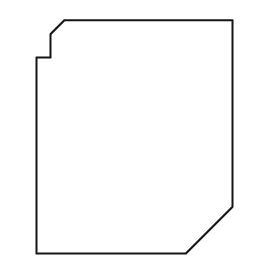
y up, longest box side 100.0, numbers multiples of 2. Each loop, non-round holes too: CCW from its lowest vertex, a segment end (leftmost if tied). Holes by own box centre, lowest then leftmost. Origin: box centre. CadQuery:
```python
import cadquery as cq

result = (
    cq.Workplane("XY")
    .moveTo(-42.0, -50.0)
    .lineTo(22.0, -50.0)
    .lineTo(42.0, -30.0)
    .lineTo(42.0, 50.0)
    .lineTo(-30.0, 50.0)
    .lineTo(-36.0, 44.0)
    .lineTo(-36.0, 34.0)
    .lineTo(-42.0, 34.0)
    .close()
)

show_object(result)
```